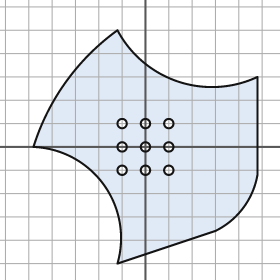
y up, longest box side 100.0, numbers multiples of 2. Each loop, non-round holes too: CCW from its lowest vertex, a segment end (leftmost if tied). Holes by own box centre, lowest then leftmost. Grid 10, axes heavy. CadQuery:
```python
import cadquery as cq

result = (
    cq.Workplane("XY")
    .moveTo(-12.0, -50.0)
    .lineTo(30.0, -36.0)
    .threePointArc((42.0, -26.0), (48.0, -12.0))
    .lineTo(48.0, 30.0)
    .threePointArc((14.0, 28.0), (-12.0, 50.0))
    .threePointArc((-34.0, 28.0), (-48.0, 0.0))
    .threePointArc((-18.0, -16.0), (-12.0, -50.0))
    .close()
    .moveTo(-10.0, -10.0)
    .circle(2.0)
    .moveTo(0.0, -10.0)
    .circle(2.0)
    .moveTo(10.0, -10.0)
    .circle(2.0)
    .moveTo(-10.0, 0.0)
    .circle(2.0)
    .moveTo(0.0, 0.0)
    .circle(2.0)
    .moveTo(10.0, 0.0)
    .circle(2.0)
    .moveTo(-10.0, 10.0)
    .circle(2.0)
    .moveTo(0.0, 10.0)
    .circle(2.0)
    .moveTo(10.0, 10.0)
    .circle(2.0)
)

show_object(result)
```